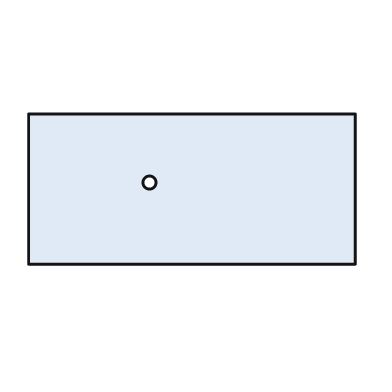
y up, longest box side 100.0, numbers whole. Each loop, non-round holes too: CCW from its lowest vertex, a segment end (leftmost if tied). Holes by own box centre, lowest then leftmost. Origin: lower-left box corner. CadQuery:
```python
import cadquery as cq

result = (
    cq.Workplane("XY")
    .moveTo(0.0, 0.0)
    .lineTo(100.0, 0.0)
    .lineTo(100.0, 46.0)
    .lineTo(0.0, 46.0)
    .close()
    .moveTo(37.0, 25.0)
    .circle(2.0)
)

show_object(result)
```